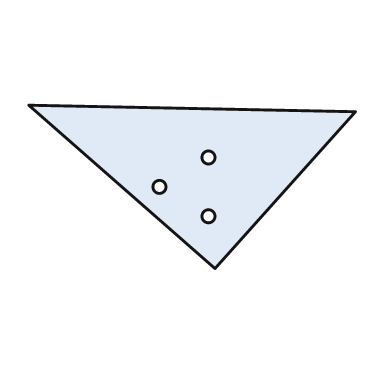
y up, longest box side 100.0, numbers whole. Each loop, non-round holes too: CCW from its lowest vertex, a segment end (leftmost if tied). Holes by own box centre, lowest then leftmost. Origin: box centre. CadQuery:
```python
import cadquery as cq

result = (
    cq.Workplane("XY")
    .moveTo(7.0, -25.0)
    .lineTo(50.0, 23.0)
    .lineTo(-50.0, 25.0)
    .close()
    .moveTo(5.0, -9.0)
    .circle(2.0)
    .moveTo(-10.0, 0.0)
    .circle(2.0)
    .moveTo(5.0, 9.0)
    .circle(2.0)
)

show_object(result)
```